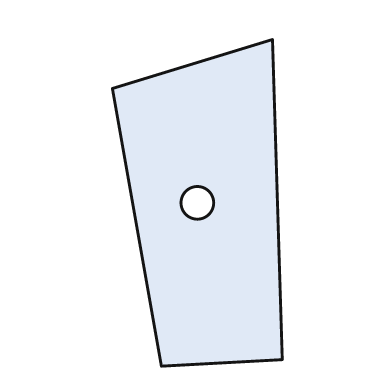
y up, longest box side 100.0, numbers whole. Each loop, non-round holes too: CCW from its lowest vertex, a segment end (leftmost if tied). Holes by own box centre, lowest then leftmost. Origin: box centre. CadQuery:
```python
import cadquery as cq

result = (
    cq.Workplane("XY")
    .moveTo(-11.0, -50.0)
    .lineTo(26.0, -48.0)
    .lineTo(23.0, 50.0)
    .lineTo(-26.0, 35.0)
    .close()
    .moveTo(0.0, 0.0)
    .circle(5.0)
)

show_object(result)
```